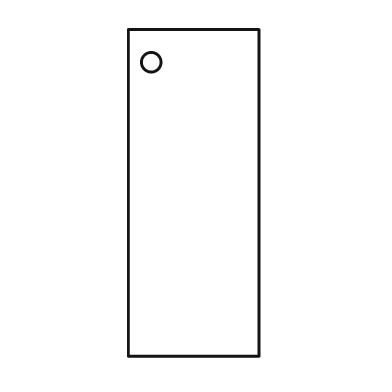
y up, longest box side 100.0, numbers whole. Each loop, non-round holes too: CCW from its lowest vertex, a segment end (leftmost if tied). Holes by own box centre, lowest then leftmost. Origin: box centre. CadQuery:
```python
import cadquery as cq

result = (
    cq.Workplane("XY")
    .moveTo(-20.0, -50.0)
    .lineTo(20.0, -50.0)
    .lineTo(20.0, 50.0)
    .lineTo(-20.0, 50.0)
    .close()
    .moveTo(-13.0, 40.0)
    .circle(3.0)
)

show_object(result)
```